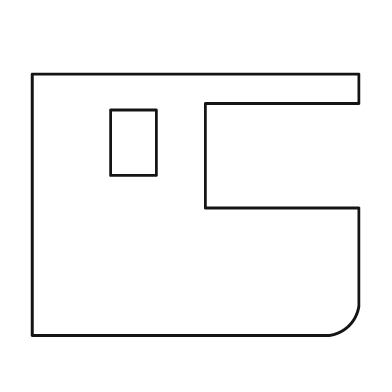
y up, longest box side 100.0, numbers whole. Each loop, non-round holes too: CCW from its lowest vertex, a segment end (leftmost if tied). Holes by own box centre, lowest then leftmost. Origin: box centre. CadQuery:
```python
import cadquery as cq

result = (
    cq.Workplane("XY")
    .moveTo(-50.0, -40.0)
    .lineTo(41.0, -40.0)
    .threePointArc((47.0, -37.0), (50.0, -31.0))
    .lineTo(50.0, -1.0)
    .lineTo(3.0, -1.0)
    .lineTo(3.0, 31.0)
    .lineTo(50.0, 31.0)
    .lineTo(50.0, 40.0)
    .lineTo(-50.0, 40.0)
    .close()
    .moveTo(-26.0, 9.0)
    .lineTo(-12.0, 9.0)
    .lineTo(-12.0, 29.0)
    .lineTo(-26.0, 29.0)
    .close()
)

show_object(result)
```